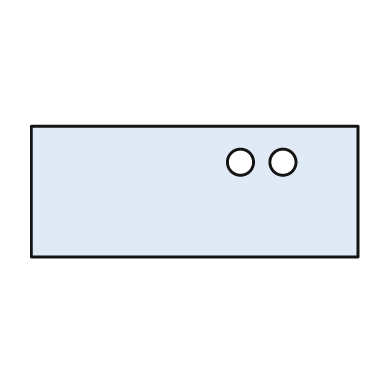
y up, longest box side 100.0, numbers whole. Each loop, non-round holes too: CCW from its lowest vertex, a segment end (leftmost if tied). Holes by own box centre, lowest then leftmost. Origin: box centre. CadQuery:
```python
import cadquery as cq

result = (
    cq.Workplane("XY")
    .moveTo(-50.0, -20.0)
    .lineTo(50.0, -20.0)
    .lineTo(50.0, 20.0)
    .lineTo(-50.0, 20.0)
    .close()
    .moveTo(14.0, 9.0)
    .circle(4.0)
    .moveTo(27.0, 9.0)
    .circle(4.0)
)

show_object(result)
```